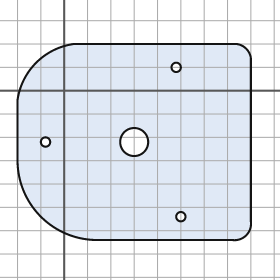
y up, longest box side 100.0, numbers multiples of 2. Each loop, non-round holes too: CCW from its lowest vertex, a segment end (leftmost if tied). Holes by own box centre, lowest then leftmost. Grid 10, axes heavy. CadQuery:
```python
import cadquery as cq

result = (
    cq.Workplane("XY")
    .moveTo(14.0, -64.0)
    .lineTo(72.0, -64.0)
    .threePointArc((78.0, -62.0), (80.0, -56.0))
    .lineTo(80.0, 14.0)
    .threePointArc((78.0, 18.0), (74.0, 20.0))
    .lineTo(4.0, 20.0)
    .threePointArc((-12.0, 12.0), (-20.0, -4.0))
    .lineTo(-20.0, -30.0)
    .threePointArc((-10.0, -54.0), (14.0, -64.0))
    .close()
    .moveTo(50.0, -54.0)
    .circle(2.0)
    .moveTo(-8.0, -22.0)
    .circle(2.0)
    .moveTo(30.0, -22.0)
    .circle(6.0)
    .moveTo(48.0, 10.0)
    .circle(2.0)
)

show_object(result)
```